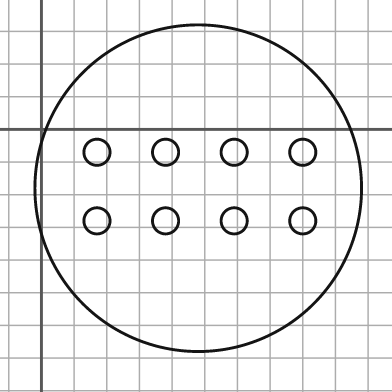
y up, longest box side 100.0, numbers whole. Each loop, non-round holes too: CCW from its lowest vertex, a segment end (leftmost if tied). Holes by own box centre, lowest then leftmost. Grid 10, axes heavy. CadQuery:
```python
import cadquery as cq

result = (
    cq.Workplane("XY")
    .moveTo(48.0, -18.0)
    .circle(50.0)
    .moveTo(17.0, -28.0)
    .circle(4.0)
    .moveTo(38.0, -28.0)
    .circle(4.0)
    .moveTo(59.0, -28.0)
    .circle(4.0)
    .moveTo(80.0, -28.0)
    .circle(4.0)
    .moveTo(17.0, -7.0)
    .circle(4.0)
    .moveTo(38.0, -7.0)
    .circle(4.0)
    .moveTo(59.0, -7.0)
    .circle(4.0)
    .moveTo(80.0, -7.0)
    .circle(4.0)
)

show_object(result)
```